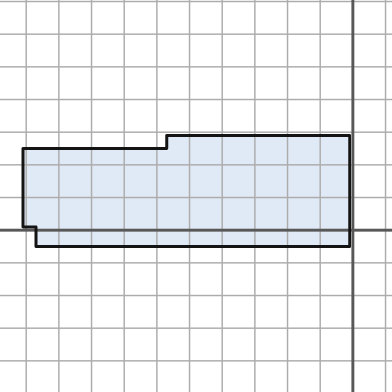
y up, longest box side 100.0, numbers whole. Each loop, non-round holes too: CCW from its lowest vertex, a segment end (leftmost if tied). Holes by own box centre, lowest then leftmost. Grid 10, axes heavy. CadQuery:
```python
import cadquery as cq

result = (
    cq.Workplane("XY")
    .moveTo(-97.0, -5.0)
    .lineTo(-1.0, -5.0)
    .lineTo(-1.0, 29.0)
    .lineTo(-57.0, 29.0)
    .lineTo(-57.0, 25.0)
    .lineTo(-101.0, 25.0)
    .lineTo(-101.0, 1.0)
    .lineTo(-97.0, 1.0)
    .close()
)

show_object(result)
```